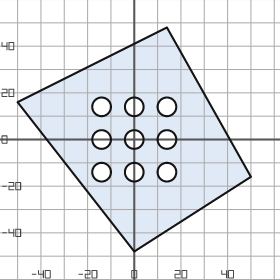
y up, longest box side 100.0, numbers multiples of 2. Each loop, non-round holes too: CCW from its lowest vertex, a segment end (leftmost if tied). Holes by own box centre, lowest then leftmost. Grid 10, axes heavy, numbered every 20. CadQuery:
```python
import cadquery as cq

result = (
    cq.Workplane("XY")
    .moveTo(0.0, -48.0)
    .lineTo(50.0, -16.0)
    .lineTo(14.0, 48.0)
    .lineTo(-50.0, 16.0)
    .close()
    .moveTo(-14.0, -14.0)
    .circle(4.0)
    .moveTo(0.0, -14.0)
    .circle(4.0)
    .moveTo(14.0, -14.0)
    .circle(4.0)
    .moveTo(-14.0, 0.0)
    .circle(4.0)
    .moveTo(0.0, 0.0)
    .circle(4.0)
    .moveTo(14.0, 0.0)
    .circle(4.0)
    .moveTo(-14.0, 14.0)
    .circle(4.0)
    .moveTo(0.0, 14.0)
    .circle(4.0)
    .moveTo(14.0, 14.0)
    .circle(4.0)
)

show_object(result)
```